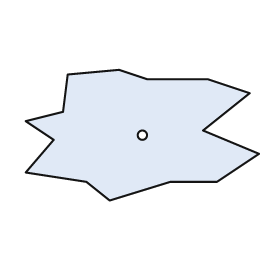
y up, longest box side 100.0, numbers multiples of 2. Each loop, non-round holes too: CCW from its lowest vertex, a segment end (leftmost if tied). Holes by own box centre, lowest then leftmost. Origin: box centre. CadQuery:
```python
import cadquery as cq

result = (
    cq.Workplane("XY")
    .moveTo(-14.0, -28.0)
    .lineTo(12.0, -20.0)
    .lineTo(32.0, -20.0)
    .lineTo(50.0, -8.0)
    .lineTo(26.0, 2.0)
    .lineTo(46.0, 18.0)
    .lineTo(28.0, 24.0)
    .lineTo(2.0, 24.0)
    .lineTo(-10.0, 28.0)
    .lineTo(-32.0, 26.0)
    .lineTo(-34.0, 10.0)
    .lineTo(-50.0, 6.0)
    .lineTo(-38.0, -2.0)
    .lineTo(-50.0, -16.0)
    .lineTo(-24.0, -20.0)
    .close()
    .moveTo(0.0, 0.0)
    .circle(2.0)
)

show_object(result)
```